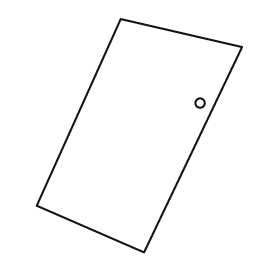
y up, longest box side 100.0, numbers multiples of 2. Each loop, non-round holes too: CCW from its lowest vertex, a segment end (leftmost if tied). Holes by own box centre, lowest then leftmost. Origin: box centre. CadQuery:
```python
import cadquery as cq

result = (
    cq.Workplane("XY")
    .moveTo(2.0, -50.0)
    .lineTo(44.0, 38.0)
    .lineTo(-8.0, 50.0)
    .lineTo(-44.0, -30.0)
    .close()
    .moveTo(26.0, 14.0)
    .circle(2.0)
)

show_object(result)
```